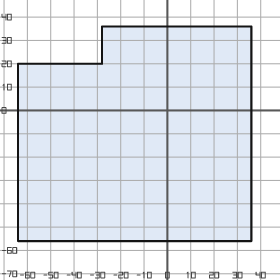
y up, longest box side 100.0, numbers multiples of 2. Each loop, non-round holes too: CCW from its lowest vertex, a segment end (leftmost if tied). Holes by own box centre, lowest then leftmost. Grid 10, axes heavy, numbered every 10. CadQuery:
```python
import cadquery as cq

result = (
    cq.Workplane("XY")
    .moveTo(-64.0, -56.0)
    .lineTo(36.0, -56.0)
    .lineTo(36.0, 36.0)
    .lineTo(-28.0, 36.0)
    .lineTo(-28.0, 20.0)
    .lineTo(-64.0, 20.0)
    .close()
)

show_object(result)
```